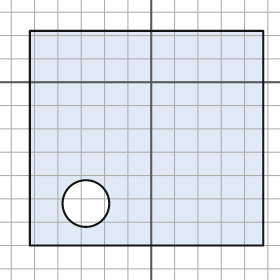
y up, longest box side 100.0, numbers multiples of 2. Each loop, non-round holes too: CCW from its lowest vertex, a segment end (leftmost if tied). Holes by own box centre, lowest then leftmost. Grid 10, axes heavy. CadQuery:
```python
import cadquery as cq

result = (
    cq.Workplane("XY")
    .moveTo(-52.0, -70.0)
    .lineTo(48.0, -70.0)
    .lineTo(48.0, 22.0)
    .lineTo(-52.0, 22.0)
    .close()
    .moveTo(-28.0, -52.0)
    .circle(10.0)
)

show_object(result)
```